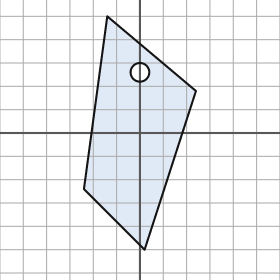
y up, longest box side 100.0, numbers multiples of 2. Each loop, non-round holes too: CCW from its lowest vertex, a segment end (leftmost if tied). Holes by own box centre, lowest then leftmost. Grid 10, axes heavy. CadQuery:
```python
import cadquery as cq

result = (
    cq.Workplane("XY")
    .moveTo(2.0, -50.0)
    .lineTo(24.0, 18.0)
    .lineTo(-14.0, 50.0)
    .lineTo(-24.0, -24.0)
    .close()
    .moveTo(0.0, 26.0)
    .circle(4.0)
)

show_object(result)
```